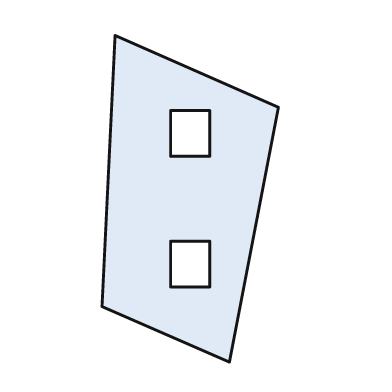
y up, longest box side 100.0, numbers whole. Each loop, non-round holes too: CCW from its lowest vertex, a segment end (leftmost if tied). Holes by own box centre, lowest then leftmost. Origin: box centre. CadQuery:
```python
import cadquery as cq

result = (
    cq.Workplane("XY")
    .moveTo(12.0, -50.0)
    .lineTo(27.0, 28.0)
    .lineTo(-23.0, 50.0)
    .lineTo(-27.0, -33.0)
    .close()
    .moveTo(-6.0, -27.0)
    .lineTo(6.0, -27.0)
    .lineTo(6.0, -13.0)
    .lineTo(-6.0, -13.0)
    .close()
    .moveTo(-6.0, 13.0)
    .lineTo(6.0, 13.0)
    .lineTo(6.0, 27.0)
    .lineTo(-6.0, 27.0)
    .close()
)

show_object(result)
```